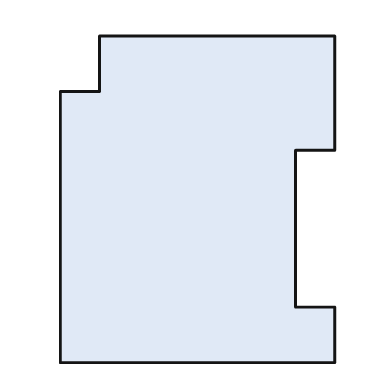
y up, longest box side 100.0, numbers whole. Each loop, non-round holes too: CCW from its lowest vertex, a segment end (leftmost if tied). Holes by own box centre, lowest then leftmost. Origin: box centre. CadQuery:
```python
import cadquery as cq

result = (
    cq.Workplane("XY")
    .moveTo(-42.0, -50.0)
    .lineTo(42.0, -50.0)
    .lineTo(42.0, -33.0)
    .lineTo(30.0, -33.0)
    .lineTo(30.0, 15.0)
    .lineTo(42.0, 15.0)
    .lineTo(42.0, 50.0)
    .lineTo(-30.0, 50.0)
    .lineTo(-30.0, 33.0)
    .lineTo(-42.0, 33.0)
    .close()
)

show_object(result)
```